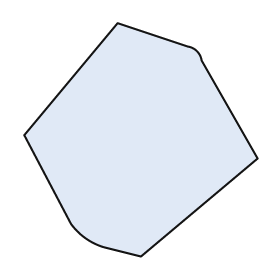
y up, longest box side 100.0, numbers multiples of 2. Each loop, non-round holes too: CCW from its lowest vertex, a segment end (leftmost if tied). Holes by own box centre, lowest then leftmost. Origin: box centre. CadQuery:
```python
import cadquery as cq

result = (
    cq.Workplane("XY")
    .moveTo(0.0, -50.0)
    .lineTo(50.0, -8.0)
    .lineTo(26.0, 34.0)
    .threePointArc((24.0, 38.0), (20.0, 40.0))
    .lineTo(-10.0, 50.0)
    .lineTo(-50.0, 2.0)
    .lineTo(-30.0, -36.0)
    .threePointArc((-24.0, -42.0), (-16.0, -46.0))
    .close()
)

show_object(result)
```